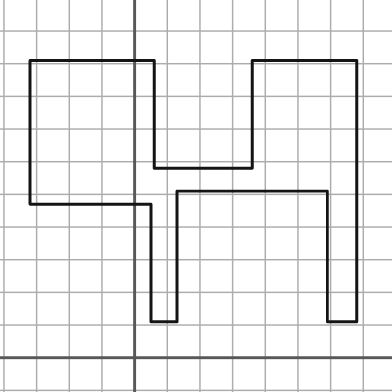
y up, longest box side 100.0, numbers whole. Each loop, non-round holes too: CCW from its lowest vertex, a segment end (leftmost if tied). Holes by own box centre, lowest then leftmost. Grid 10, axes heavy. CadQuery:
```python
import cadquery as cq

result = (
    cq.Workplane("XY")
    .moveTo(5.0, 11.0)
    .lineTo(13.0, 11.0)
    .lineTo(13.0, 51.0)
    .lineTo(59.0, 51.0)
    .lineTo(59.0, 11.0)
    .lineTo(68.0, 11.0)
    .lineTo(68.0, 91.0)
    .lineTo(36.0, 91.0)
    .lineTo(36.0, 58.0)
    .lineTo(6.0, 58.0)
    .lineTo(6.0, 91.0)
    .lineTo(-32.0, 91.0)
    .lineTo(-32.0, 47.0)
    .lineTo(5.0, 47.0)
    .close()
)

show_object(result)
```